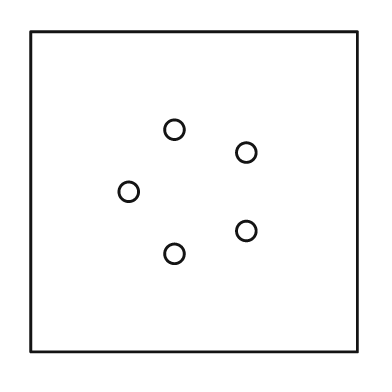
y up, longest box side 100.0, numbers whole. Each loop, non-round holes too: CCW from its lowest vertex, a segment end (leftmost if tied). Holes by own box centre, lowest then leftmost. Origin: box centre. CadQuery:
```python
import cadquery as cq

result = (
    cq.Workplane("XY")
    .moveTo(-50.0, -49.0)
    .lineTo(50.0, -49.0)
    .lineTo(50.0, 49.0)
    .lineTo(-50.0, 49.0)
    .close()
    .moveTo(-6.0, -19.0)
    .circle(3.0)
    .moveTo(16.0, -12.0)
    .circle(3.0)
    .moveTo(-20.0, 0.0)
    .circle(3.0)
    .moveTo(16.0, 12.0)
    .circle(3.0)
    .moveTo(-6.0, 19.0)
    .circle(3.0)
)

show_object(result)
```